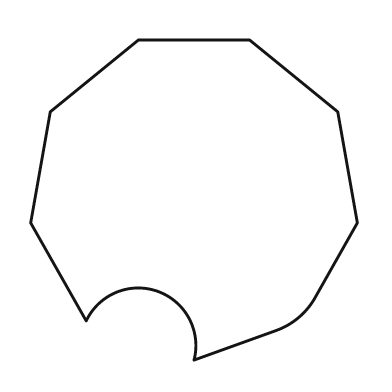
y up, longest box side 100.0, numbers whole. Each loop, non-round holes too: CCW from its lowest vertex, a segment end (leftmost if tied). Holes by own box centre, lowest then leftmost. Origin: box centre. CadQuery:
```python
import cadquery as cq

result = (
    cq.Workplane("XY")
    .moveTo(0.0, -49.0)
    .lineTo(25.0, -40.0)
    .threePointArc((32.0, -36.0), (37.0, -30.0))
    .lineTo(50.0, -7.0)
    .lineTo(44.0, 27.0)
    .lineTo(17.0, 49.0)
    .lineTo(-17.0, 49.0)
    .lineTo(-44.0, 27.0)
    .lineTo(-50.0, -7.0)
    .lineTo(-33.0, -37.0)
    .threePointArc((-11.0, -28.0), (0.0, -49.0))
    .close()
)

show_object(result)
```